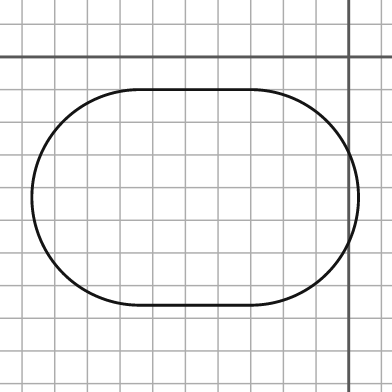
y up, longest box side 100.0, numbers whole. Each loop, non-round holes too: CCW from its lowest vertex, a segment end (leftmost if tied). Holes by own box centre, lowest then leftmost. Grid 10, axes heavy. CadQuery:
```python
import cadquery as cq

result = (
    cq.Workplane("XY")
    .moveTo(-64.0, -76.0)
    .lineTo(-30.0, -76.0)
    .threePointArc((3.0, -43.0), (-30.0, -10.0))
    .lineTo(-64.0, -10.0)
    .threePointArc((-97.0, -43.0), (-64.0, -76.0))
    .close()
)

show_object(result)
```